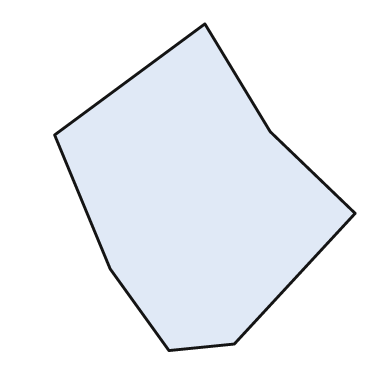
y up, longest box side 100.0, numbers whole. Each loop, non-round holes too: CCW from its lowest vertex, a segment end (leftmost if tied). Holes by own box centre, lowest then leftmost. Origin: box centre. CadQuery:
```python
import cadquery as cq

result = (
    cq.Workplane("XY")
    .moveTo(-11.0, -50.0)
    .lineTo(9.0, -48.0)
    .lineTo(46.0, -8.0)
    .lineTo(20.0, 17.0)
    .lineTo(0.0, 50.0)
    .lineTo(-46.0, 16.0)
    .lineTo(-29.0, -25.0)
    .close()
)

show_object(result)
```